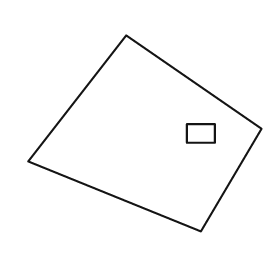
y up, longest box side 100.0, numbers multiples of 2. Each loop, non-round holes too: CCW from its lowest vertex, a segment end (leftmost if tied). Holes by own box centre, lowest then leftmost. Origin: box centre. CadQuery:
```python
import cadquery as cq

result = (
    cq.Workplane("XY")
    .moveTo(24.0, -42.0)
    .lineTo(50.0, 2.0)
    .lineTo(-8.0, 42.0)
    .lineTo(-50.0, -12.0)
    .close()
    .moveTo(18.0, -4.0)
    .lineTo(30.0, -4.0)
    .lineTo(30.0, 4.0)
    .lineTo(18.0, 4.0)
    .close()
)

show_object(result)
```